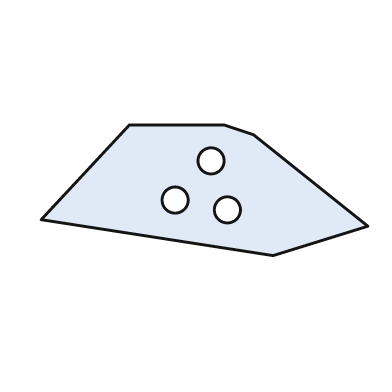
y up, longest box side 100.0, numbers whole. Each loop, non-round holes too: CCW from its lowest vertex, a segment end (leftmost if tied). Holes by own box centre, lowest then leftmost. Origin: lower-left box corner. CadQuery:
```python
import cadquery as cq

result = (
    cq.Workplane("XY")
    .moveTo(71.0, 0.0)
    .lineTo(100.0, 9.0)
    .lineTo(65.0, 37.0)
    .lineTo(56.0, 40.0)
    .lineTo(27.0, 40.0)
    .lineTo(0.0, 11.0)
    .close()
    .moveTo(57.0, 14.0)
    .circle(4.0)
    .moveTo(41.0, 17.0)
    .circle(4.0)
    .moveTo(52.0, 29.0)
    .circle(4.0)
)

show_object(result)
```